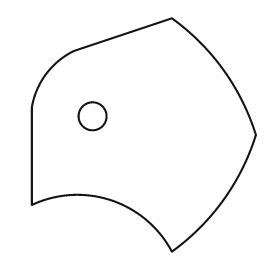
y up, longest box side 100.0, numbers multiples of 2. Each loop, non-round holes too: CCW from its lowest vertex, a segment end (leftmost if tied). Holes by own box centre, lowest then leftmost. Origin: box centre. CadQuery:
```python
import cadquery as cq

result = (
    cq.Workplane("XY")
    .moveTo(12.0, -50.0)
    .threePointArc((34.0, -28.0), (48.0, 0.0))
    .threePointArc((34.0, 28.0), (12.0, 50.0))
    .lineTo(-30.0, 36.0)
    .threePointArc((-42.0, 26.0), (-48.0, 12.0))
    .lineTo(-48.0, -30.0)
    .threePointArc((-14.0, -28.0), (12.0, -50.0))
    .close()
    .moveTo(-22.0, 8.0)
    .circle(6.0)
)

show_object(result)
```